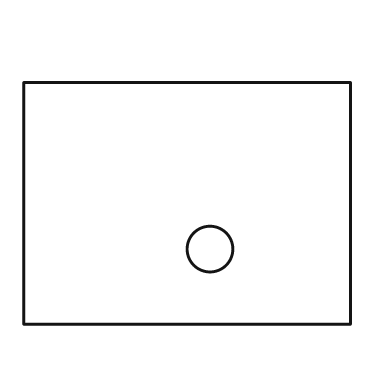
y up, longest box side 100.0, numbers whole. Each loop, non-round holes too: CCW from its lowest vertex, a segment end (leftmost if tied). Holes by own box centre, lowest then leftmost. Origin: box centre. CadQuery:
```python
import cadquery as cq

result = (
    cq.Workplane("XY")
    .moveTo(-50.0, -37.0)
    .lineTo(50.0, -37.0)
    .lineTo(50.0, 37.0)
    .lineTo(-50.0, 37.0)
    .close()
    .moveTo(7.0, -14.0)
    .circle(7.0)
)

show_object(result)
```